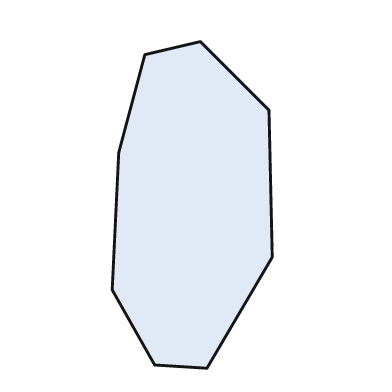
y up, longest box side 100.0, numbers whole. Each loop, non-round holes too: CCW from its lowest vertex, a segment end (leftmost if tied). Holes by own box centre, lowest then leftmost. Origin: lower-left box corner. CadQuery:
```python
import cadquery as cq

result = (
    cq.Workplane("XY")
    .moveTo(29.0, 0.0)
    .lineTo(49.0, 34.0)
    .lineTo(48.0, 79.0)
    .lineTo(27.0, 100.0)
    .lineTo(10.0, 96.0)
    .lineTo(2.0, 66.0)
    .lineTo(0.0, 24.0)
    .lineTo(13.0, 1.0)
    .close()
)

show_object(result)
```